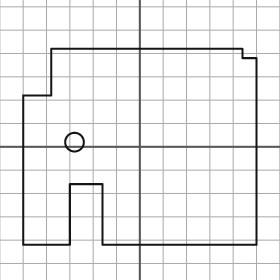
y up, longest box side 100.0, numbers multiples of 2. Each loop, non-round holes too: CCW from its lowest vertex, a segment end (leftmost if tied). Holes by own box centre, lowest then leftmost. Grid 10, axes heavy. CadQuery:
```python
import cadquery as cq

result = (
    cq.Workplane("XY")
    .moveTo(-50.0, -42.0)
    .lineTo(-30.0, -42.0)
    .lineTo(-30.0, -16.0)
    .lineTo(-16.0, -16.0)
    .lineTo(-16.0, -42.0)
    .lineTo(50.0, -42.0)
    .lineTo(50.0, 38.0)
    .lineTo(44.0, 38.0)
    .lineTo(44.0, 42.0)
    .lineTo(-38.0, 42.0)
    .lineTo(-38.0, 22.0)
    .lineTo(-50.0, 22.0)
    .close()
    .moveTo(-28.0, 2.0)
    .circle(4.0)
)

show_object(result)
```